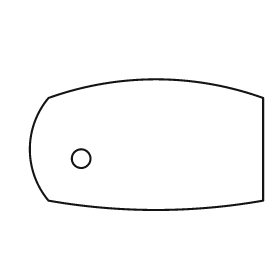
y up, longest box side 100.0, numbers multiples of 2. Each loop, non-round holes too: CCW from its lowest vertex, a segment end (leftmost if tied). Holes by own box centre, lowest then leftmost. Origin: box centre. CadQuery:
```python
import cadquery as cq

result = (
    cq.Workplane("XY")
    .moveTo(-42.0, -24.0)
    .threePointArc((4.0, -28.0), (50.0, -24.0))
    .lineTo(50.0, 20.0)
    .threePointArc((4.0, 28.0), (-42.0, 20.0))
    .threePointArc((-50.0, -2.0), (-42.0, -24.0))
    .close()
    .moveTo(-28.0, -6.0)
    .circle(4.0)
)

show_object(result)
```